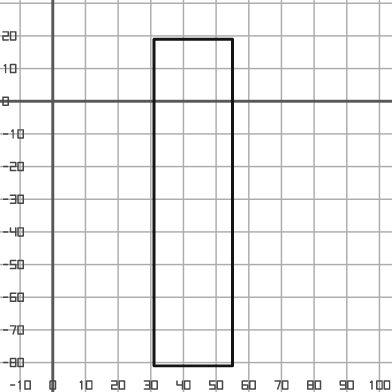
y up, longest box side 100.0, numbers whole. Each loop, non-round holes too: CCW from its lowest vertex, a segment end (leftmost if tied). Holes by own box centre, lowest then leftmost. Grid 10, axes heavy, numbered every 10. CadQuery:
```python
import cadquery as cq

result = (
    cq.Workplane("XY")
    .moveTo(31.0, -81.0)
    .lineTo(55.0, -81.0)
    .lineTo(55.0, 19.0)
    .lineTo(31.0, 19.0)
    .close()
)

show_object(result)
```